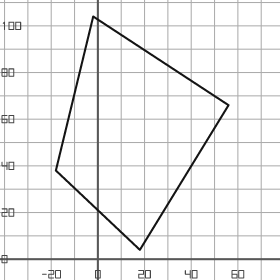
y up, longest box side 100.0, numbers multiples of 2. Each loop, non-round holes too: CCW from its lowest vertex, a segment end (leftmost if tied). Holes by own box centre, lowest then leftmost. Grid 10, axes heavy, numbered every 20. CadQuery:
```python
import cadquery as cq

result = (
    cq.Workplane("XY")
    .moveTo(18.0, 4.0)
    .lineTo(56.0, 66.0)
    .lineTo(-2.0, 104.0)
    .lineTo(-18.0, 38.0)
    .close()
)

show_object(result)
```